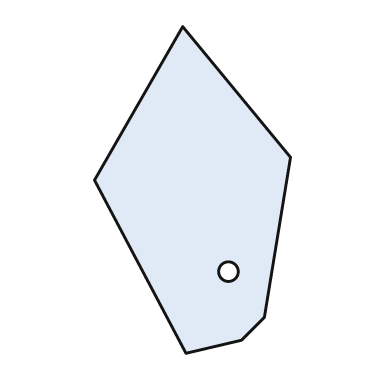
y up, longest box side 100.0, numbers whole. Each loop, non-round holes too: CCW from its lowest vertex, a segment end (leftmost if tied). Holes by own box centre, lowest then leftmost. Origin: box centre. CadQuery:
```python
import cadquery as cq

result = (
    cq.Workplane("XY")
    .moveTo(-2.0, -50.0)
    .lineTo(15.0, -46.0)
    .lineTo(22.0, -39.0)
    .lineTo(30.0, 10.0)
    .lineTo(-3.0, 50.0)
    .lineTo(-30.0, 3.0)
    .close()
    .moveTo(11.0, -25.0)
    .circle(3.0)
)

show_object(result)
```